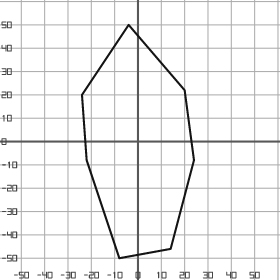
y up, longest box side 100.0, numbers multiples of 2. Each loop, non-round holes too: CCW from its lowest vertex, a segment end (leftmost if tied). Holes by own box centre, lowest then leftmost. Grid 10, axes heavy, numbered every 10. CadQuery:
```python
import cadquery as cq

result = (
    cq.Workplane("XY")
    .moveTo(-8.0, -50.0)
    .lineTo(14.0, -46.0)
    .lineTo(24.0, -8.0)
    .lineTo(20.0, 22.0)
    .lineTo(-4.0, 50.0)
    .lineTo(-24.0, 20.0)
    .lineTo(-22.0, -8.0)
    .close()
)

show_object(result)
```